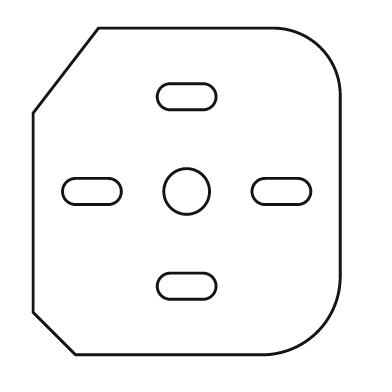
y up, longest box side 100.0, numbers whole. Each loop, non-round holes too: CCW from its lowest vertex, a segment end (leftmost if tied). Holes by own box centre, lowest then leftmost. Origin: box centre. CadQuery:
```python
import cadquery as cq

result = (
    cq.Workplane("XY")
    .moveTo(-34.0, -50.0)
    .lineTo(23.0, -50.0)
    .threePointArc((40.0, -43.0), (47.0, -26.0))
    .lineTo(47.0, 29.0)
    .threePointArc((41.0, 44.0), (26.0, 50.0))
    .lineTo(-27.0, 50.0)
    .lineTo(-47.0, 24.0)
    .lineTo(-47.0, -37.0)
    .close()
    .moveTo(-5.0, -33.0)
    .lineTo(5.0, -33.0)
    .threePointArc((9.0, -29.0), (5.0, -25.0))
    .lineTo(-5.0, -25.0)
    .threePointArc((-9.0, -29.0), (-5.0, -33.0))
    .close()
    .moveTo(-34.0, -4.0)
    .lineTo(-24.0, -4.0)
    .threePointArc((-20.0, 0.0), (-24.0, 4.0))
    .lineTo(-34.0, 4.0)
    .threePointArc((-38.0, 0.0), (-34.0, -4.0))
    .close()
    .moveTo(0.0, 0.0)
    .circle(7.0)
    .moveTo(24.0, -4.0)
    .lineTo(34.0, -4.0)
    .threePointArc((38.0, 0.0), (34.0, 4.0))
    .lineTo(24.0, 4.0)
    .threePointArc((20.0, 0.0), (24.0, -4.0))
    .close()
    .moveTo(-5.0, 25.0)
    .lineTo(5.0, 25.0)
    .threePointArc((9.0, 29.0), (5.0, 33.0))
    .lineTo(-5.0, 33.0)
    .threePointArc((-9.0, 29.0), (-5.0, 25.0))
    .close()
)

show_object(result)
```